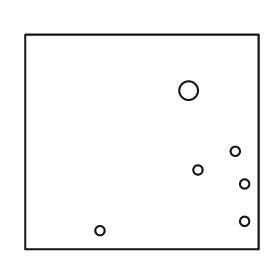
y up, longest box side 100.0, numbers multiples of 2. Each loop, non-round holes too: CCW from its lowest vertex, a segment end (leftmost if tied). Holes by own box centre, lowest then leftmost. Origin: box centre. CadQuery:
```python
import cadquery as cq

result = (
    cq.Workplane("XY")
    .moveTo(-50.0, -46.0)
    .lineTo(50.0, -46.0)
    .lineTo(50.0, 46.0)
    .lineTo(-50.0, 46.0)
    .close()
    .moveTo(-18.0, -38.0)
    .circle(2.0)
    .moveTo(44.0, -34.0)
    .circle(2.0)
    .moveTo(44.0, -18.0)
    .circle(2.0)
    .moveTo(24.0, -12.0)
    .circle(2.0)
    .moveTo(40.0, -4.0)
    .circle(2.0)
    .moveTo(20.0, 22.0)
    .circle(4.0)
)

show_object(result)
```